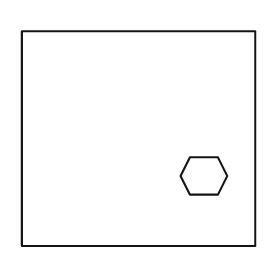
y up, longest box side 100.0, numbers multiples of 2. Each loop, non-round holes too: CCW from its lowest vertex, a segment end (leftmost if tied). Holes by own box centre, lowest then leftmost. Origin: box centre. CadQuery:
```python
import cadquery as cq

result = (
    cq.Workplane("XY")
    .moveTo(-50.0, -46.0)
    .lineTo(50.0, -46.0)
    .lineTo(50.0, 46.0)
    .lineTo(-50.0, 46.0)
    .close()
    .moveTo(22.0, -24.0)
    .lineTo(34.0, -24.0)
    .lineTo(38.0, -16.0)
    .lineTo(34.0, -8.0)
    .lineTo(22.0, -8.0)
    .lineTo(18.0, -16.0)
    .close()
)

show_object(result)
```